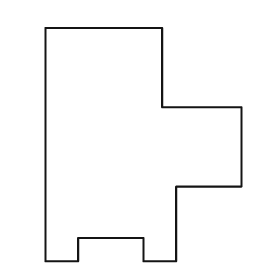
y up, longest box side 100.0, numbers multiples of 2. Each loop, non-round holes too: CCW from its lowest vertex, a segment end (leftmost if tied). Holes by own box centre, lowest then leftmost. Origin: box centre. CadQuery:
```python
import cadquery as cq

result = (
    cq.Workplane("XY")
    .moveTo(-42.0, -50.0)
    .lineTo(-28.0, -50.0)
    .lineTo(-28.0, -40.0)
    .lineTo(0.0, -40.0)
    .lineTo(0.0, -50.0)
    .lineTo(14.0, -50.0)
    .lineTo(14.0, -18.0)
    .lineTo(42.0, -18.0)
    .lineTo(42.0, 16.0)
    .lineTo(8.0, 16.0)
    .lineTo(8.0, 50.0)
    .lineTo(-42.0, 50.0)
    .close()
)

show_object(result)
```